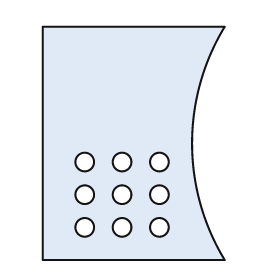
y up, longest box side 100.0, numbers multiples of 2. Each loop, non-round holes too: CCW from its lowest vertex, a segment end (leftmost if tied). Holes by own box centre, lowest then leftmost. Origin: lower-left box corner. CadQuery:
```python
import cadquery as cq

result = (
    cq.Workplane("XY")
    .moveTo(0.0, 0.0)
    .lineTo(78.0, 0.0)
    .threePointArc((64.0, 50.0), (78.0, 100.0))
    .lineTo(0.0, 100.0)
    .close()
    .moveTo(18.0, 14.0)
    .circle(4.0)
    .moveTo(34.0, 14.0)
    .circle(4.0)
    .moveTo(50.0, 14.0)
    .circle(4.0)
    .moveTo(18.0, 28.0)
    .circle(4.0)
    .moveTo(34.0, 28.0)
    .circle(4.0)
    .moveTo(50.0, 28.0)
    .circle(4.0)
    .moveTo(18.0, 42.0)
    .circle(4.0)
    .moveTo(34.0, 42.0)
    .circle(4.0)
    .moveTo(50.0, 42.0)
    .circle(4.0)
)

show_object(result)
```